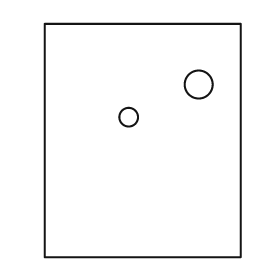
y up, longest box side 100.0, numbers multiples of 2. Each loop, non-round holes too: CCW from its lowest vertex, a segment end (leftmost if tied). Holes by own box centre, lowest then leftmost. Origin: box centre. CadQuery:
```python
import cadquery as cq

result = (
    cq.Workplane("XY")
    .moveTo(-42.0, -50.0)
    .lineTo(42.0, -50.0)
    .lineTo(42.0, 50.0)
    .lineTo(-42.0, 50.0)
    .close()
    .moveTo(-6.0, 10.0)
    .circle(4.0)
    .moveTo(24.0, 24.0)
    .circle(6.0)
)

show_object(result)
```